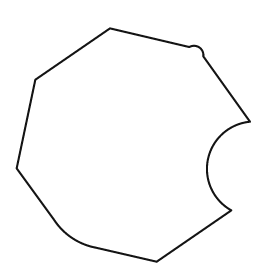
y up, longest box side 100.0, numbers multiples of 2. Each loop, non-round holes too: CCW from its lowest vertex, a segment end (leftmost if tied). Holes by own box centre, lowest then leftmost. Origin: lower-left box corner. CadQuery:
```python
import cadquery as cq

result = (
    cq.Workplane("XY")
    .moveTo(60.0, 0.0)
    .lineTo(92.0, 22.0)
    .threePointArc((82.0, 44.0), (100.0, 60.0))
    .lineTo(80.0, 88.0)
    .threePointArc((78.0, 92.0), (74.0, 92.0))
    .lineTo(40.0, 100.0)
    .lineTo(8.0, 78.0)
    .lineTo(0.0, 40.0)
    .lineTo(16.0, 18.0)
    .threePointArc((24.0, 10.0), (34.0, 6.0))
    .close()
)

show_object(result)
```